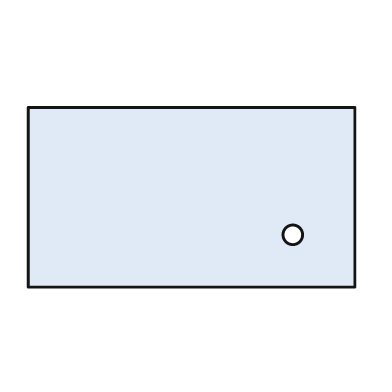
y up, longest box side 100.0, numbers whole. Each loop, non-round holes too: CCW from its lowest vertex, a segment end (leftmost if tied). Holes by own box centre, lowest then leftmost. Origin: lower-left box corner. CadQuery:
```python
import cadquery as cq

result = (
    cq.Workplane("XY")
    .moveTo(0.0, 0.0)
    .lineTo(100.0, 0.0)
    .lineTo(100.0, 55.0)
    .lineTo(0.0, 55.0)
    .close()
    .moveTo(81.0, 16.0)
    .circle(3.0)
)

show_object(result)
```